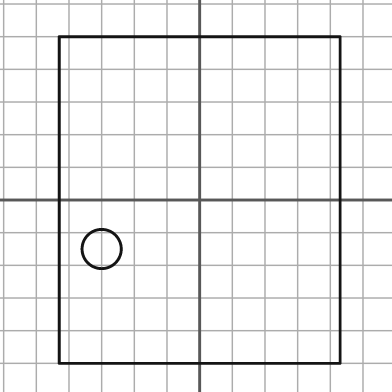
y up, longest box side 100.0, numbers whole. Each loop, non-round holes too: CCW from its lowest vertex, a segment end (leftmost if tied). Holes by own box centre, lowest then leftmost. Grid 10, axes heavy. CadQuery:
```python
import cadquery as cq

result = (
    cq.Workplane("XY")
    .moveTo(-43.0, -50.0)
    .lineTo(43.0, -50.0)
    .lineTo(43.0, 50.0)
    .lineTo(-43.0, 50.0)
    .close()
    .moveTo(-30.0, -15.0)
    .circle(6.0)
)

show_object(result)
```